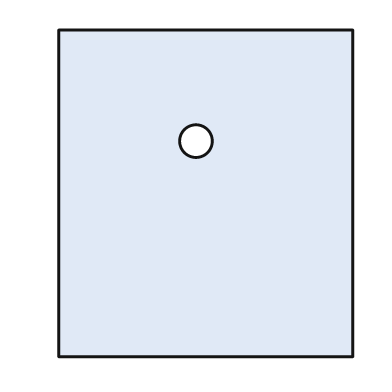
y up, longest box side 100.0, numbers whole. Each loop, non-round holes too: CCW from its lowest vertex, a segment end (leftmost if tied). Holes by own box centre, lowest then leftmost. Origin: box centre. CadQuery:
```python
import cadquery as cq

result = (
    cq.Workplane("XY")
    .moveTo(-45.0, -50.0)
    .lineTo(45.0, -50.0)
    .lineTo(45.0, 50.0)
    .lineTo(-45.0, 50.0)
    .close()
    .moveTo(-3.0, 16.0)
    .circle(5.0)
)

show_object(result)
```